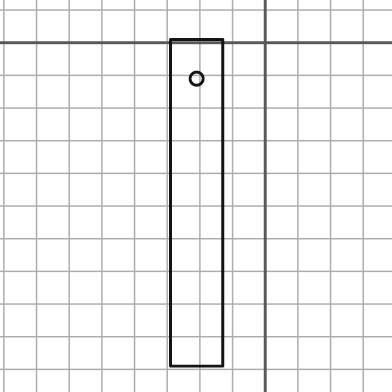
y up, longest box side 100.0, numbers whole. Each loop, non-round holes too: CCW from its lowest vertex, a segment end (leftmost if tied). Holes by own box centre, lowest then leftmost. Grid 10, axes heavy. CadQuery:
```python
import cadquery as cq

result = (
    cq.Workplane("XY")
    .moveTo(-29.0, -99.0)
    .lineTo(-13.0, -99.0)
    .lineTo(-13.0, 1.0)
    .lineTo(-29.0, 1.0)
    .close()
    .moveTo(-21.0, -11.0)
    .circle(2.0)
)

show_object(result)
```